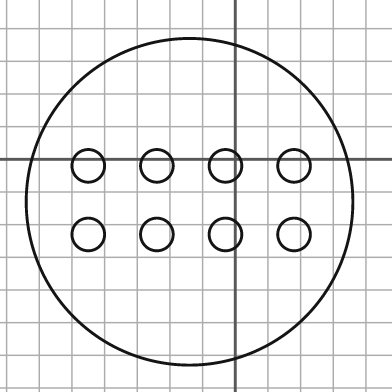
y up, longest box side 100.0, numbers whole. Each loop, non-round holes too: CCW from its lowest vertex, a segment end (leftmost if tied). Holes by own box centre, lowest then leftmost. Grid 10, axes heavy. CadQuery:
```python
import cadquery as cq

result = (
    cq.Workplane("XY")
    .moveTo(-14.0, -13.0)
    .circle(50.0)
    .moveTo(-45.0, -23.0)
    .circle(5.0)
    .moveTo(-24.0, -23.0)
    .circle(5.0)
    .moveTo(-3.0, -23.0)
    .circle(5.0)
    .moveTo(18.0, -23.0)
    .circle(5.0)
    .moveTo(-45.0, -2.0)
    .circle(5.0)
    .moveTo(-24.0, -2.0)
    .circle(5.0)
    .moveTo(-3.0, -2.0)
    .circle(5.0)
    .moveTo(18.0, -2.0)
    .circle(5.0)
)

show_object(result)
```